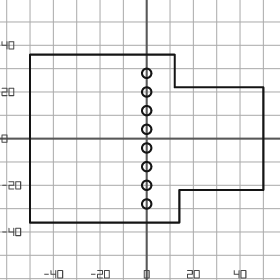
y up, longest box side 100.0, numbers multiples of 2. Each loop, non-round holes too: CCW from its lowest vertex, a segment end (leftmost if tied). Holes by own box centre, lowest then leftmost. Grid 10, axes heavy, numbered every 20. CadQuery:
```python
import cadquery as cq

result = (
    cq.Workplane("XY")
    .moveTo(-50.0, -36.0)
    .lineTo(14.0, -36.0)
    .lineTo(14.0, -22.0)
    .lineTo(50.0, -22.0)
    .lineTo(50.0, 22.0)
    .lineTo(12.0, 22.0)
    .lineTo(12.0, 36.0)
    .lineTo(-50.0, 36.0)
    .close()
    .moveTo(0.0, -28.0)
    .circle(2.0)
    .moveTo(0.0, -20.0)
    .circle(2.0)
    .moveTo(0.0, -12.0)
    .circle(2.0)
    .moveTo(0.0, -4.0)
    .circle(2.0)
    .moveTo(0.0, 4.0)
    .circle(2.0)
    .moveTo(0.0, 12.0)
    .circle(2.0)
    .moveTo(0.0, 20.0)
    .circle(2.0)
    .moveTo(0.0, 28.0)
    .circle(2.0)
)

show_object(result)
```